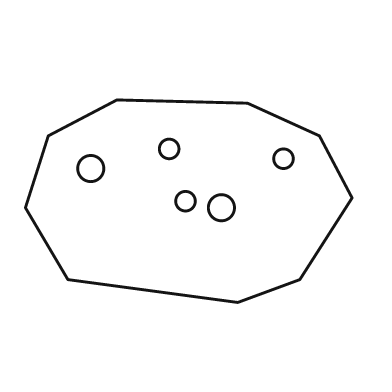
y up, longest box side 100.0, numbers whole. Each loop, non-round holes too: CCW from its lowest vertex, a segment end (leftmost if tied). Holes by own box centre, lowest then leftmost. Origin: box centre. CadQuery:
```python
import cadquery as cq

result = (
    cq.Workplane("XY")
    .moveTo(15.0, -31.0)
    .lineTo(34.0, -24.0)
    .lineTo(50.0, 1.0)
    .lineTo(40.0, 20.0)
    .lineTo(18.0, 30.0)
    .lineTo(-22.0, 31.0)
    .lineTo(-43.0, 20.0)
    .lineTo(-50.0, -2.0)
    .lineTo(-37.0, -24.0)
    .close()
    .moveTo(10.0, -2.0)
    .circle(4.0)
    .moveTo(-1.0, 0.0)
    .circle(3.0)
    .moveTo(-30.0, 10.0)
    .circle(4.0)
    .moveTo(29.0, 13.0)
    .circle(3.0)
    .moveTo(-6.0, 16.0)
    .circle(3.0)
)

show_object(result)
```